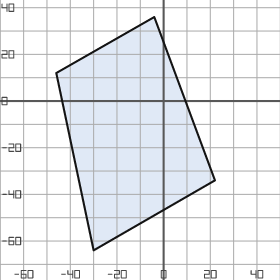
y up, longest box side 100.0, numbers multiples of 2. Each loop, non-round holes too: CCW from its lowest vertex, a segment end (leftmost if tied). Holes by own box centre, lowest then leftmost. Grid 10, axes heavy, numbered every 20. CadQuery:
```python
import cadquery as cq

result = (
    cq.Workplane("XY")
    .moveTo(-30.0, -64.0)
    .lineTo(22.0, -34.0)
    .lineTo(-4.0, 36.0)
    .lineTo(-46.0, 12.0)
    .close()
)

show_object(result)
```